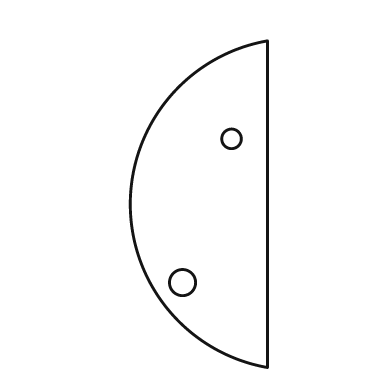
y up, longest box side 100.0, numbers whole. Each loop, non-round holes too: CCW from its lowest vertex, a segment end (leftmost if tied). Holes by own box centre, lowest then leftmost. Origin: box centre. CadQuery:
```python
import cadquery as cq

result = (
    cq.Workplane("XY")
    .moveTo(21.0, -50.0)
    .lineTo(21.0, 50.0)
    .threePointArc((-21.0, 0.0), (21.0, -50.0))
    .close()
    .moveTo(-5.0, -24.0)
    .circle(4.0)
    .moveTo(10.0, 20.0)
    .circle(3.0)
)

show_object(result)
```